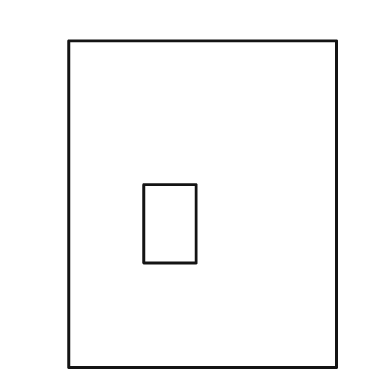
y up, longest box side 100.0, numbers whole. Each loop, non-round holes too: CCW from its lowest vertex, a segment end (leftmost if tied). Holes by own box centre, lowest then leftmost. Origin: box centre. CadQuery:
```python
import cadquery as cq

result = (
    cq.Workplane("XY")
    .moveTo(-41.0, -50.0)
    .lineTo(41.0, -50.0)
    .lineTo(41.0, 50.0)
    .lineTo(-41.0, 50.0)
    .close()
    .moveTo(-18.0, -18.0)
    .lineTo(-2.0, -18.0)
    .lineTo(-2.0, 6.0)
    .lineTo(-18.0, 6.0)
    .close()
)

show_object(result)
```